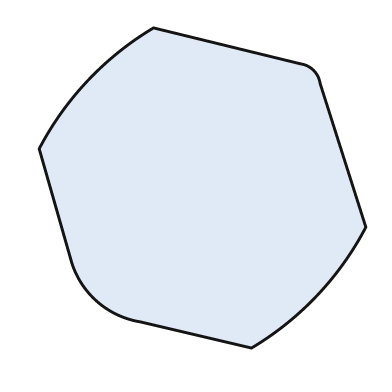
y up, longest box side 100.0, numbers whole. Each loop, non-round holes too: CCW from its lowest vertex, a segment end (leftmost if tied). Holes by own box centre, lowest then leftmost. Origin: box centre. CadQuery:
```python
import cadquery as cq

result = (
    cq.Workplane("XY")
    .moveTo(15.0, -49.0)
    .threePointArc((35.0, -33.0), (50.0, -12.0))
    .lineTo(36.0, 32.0)
    .threePointArc((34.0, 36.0), (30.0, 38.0))
    .lineTo(-15.0, 49.0)
    .threePointArc((-35.0, 33.0), (-50.0, 12.0))
    .lineTo(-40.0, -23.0)
    .threePointArc((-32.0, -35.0), (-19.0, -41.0))
    .close()
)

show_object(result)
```